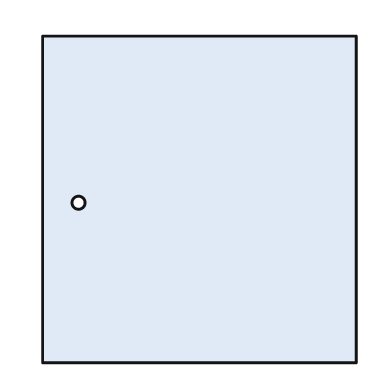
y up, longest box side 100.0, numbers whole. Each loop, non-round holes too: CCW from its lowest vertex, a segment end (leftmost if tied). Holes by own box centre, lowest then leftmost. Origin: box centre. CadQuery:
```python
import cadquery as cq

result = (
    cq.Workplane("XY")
    .moveTo(-48.0, -50.0)
    .lineTo(48.0, -50.0)
    .lineTo(48.0, 50.0)
    .lineTo(-48.0, 50.0)
    .close()
    .moveTo(-37.0, -1.0)
    .circle(2.0)
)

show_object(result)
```